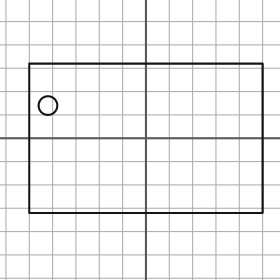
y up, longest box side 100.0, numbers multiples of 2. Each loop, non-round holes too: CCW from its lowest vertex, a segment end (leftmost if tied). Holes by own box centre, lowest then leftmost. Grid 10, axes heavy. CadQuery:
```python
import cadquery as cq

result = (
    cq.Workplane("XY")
    .moveTo(-50.0, -32.0)
    .lineTo(50.0, -32.0)
    .lineTo(50.0, 32.0)
    .lineTo(-50.0, 32.0)
    .close()
    .moveTo(-42.0, 14.0)
    .circle(4.0)
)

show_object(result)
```